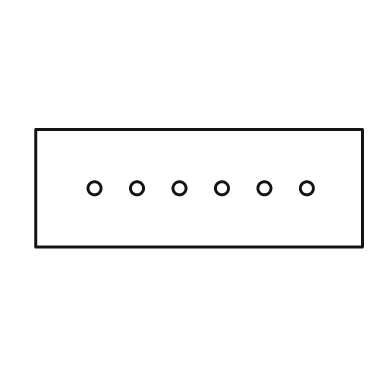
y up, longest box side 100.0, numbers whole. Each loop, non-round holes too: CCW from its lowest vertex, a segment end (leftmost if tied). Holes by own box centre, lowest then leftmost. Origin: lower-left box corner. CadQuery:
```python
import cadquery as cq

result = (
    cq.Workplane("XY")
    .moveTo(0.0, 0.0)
    .lineTo(100.0, 0.0)
    .lineTo(100.0, 36.0)
    .lineTo(0.0, 36.0)
    .close()
    .moveTo(18.0, 18.0)
    .circle(2.0)
    .moveTo(31.0, 18.0)
    .circle(2.0)
    .moveTo(44.0, 18.0)
    .circle(2.0)
    .moveTo(57.0, 18.0)
    .circle(2.0)
    .moveTo(70.0, 18.0)
    .circle(2.0)
    .moveTo(83.0, 18.0)
    .circle(2.0)
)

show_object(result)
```